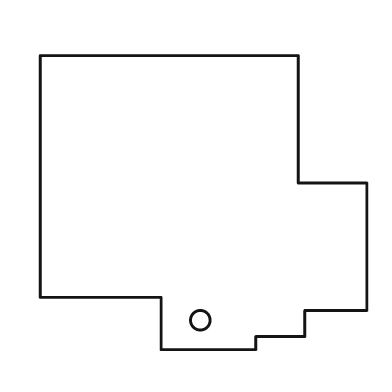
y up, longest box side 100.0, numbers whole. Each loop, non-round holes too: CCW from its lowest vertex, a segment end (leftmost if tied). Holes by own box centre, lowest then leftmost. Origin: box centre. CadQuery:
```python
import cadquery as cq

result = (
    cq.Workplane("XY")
    .moveTo(-13.0, -45.0)
    .lineTo(16.0, -45.0)
    .lineTo(16.0, -41.0)
    .lineTo(31.0, -41.0)
    .lineTo(31.0, -33.0)
    .lineTo(50.0, -33.0)
    .lineTo(50.0, 6.0)
    .lineTo(29.0, 6.0)
    .lineTo(29.0, 45.0)
    .lineTo(-50.0, 45.0)
    .lineTo(-50.0, -29.0)
    .lineTo(-13.0, -29.0)
    .close()
    .moveTo(-1.0, -36.0)
    .circle(3.0)
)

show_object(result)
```